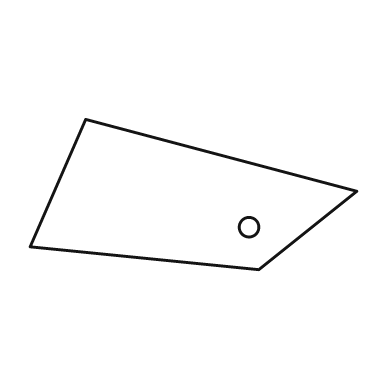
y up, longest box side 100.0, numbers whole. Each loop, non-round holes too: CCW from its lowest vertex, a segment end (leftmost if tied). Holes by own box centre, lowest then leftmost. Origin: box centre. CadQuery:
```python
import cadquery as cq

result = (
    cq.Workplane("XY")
    .moveTo(20.0, -23.0)
    .lineTo(50.0, 1.0)
    .lineTo(-33.0, 23.0)
    .lineTo(-50.0, -16.0)
    .close()
    .moveTo(17.0, -10.0)
    .circle(3.0)
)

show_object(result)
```